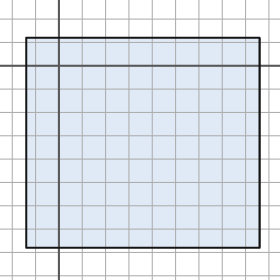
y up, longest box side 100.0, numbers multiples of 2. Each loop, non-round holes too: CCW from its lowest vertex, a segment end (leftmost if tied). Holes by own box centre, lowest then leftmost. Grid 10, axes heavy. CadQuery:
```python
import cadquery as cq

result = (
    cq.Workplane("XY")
    .moveTo(-14.0, -78.0)
    .lineTo(86.0, -78.0)
    .lineTo(86.0, 12.0)
    .lineTo(-14.0, 12.0)
    .close()
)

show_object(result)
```